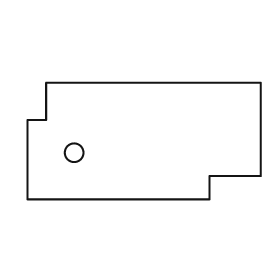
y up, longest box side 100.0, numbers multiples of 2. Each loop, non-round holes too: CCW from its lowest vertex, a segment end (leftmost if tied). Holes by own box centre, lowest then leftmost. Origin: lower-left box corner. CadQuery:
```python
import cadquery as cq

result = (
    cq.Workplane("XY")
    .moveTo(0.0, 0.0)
    .lineTo(78.0, 0.0)
    .lineTo(78.0, 10.0)
    .lineTo(100.0, 10.0)
    .lineTo(100.0, 50.0)
    .lineTo(8.0, 50.0)
    .lineTo(8.0, 34.0)
    .lineTo(0.0, 34.0)
    .close()
    .moveTo(20.0, 20.0)
    .circle(4.0)
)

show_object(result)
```